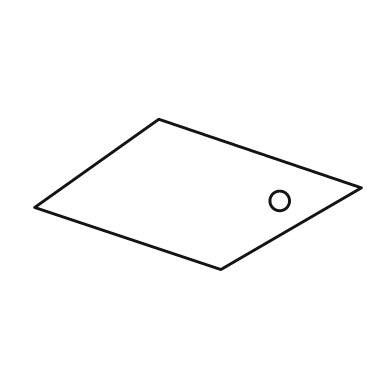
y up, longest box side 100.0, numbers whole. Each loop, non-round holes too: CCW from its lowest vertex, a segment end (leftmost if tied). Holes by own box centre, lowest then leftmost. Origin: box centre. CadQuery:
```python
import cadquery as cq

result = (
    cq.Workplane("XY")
    .moveTo(7.0, -23.0)
    .lineTo(50.0, 2.0)
    .lineTo(-12.0, 23.0)
    .lineTo(-50.0, -4.0)
    .close()
    .moveTo(25.0, -2.0)
    .circle(3.0)
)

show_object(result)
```